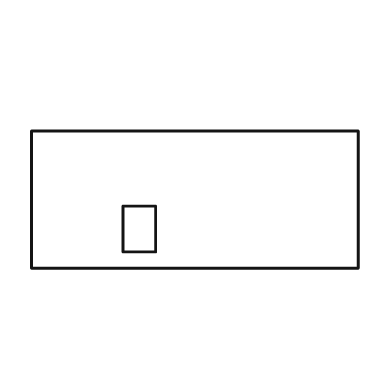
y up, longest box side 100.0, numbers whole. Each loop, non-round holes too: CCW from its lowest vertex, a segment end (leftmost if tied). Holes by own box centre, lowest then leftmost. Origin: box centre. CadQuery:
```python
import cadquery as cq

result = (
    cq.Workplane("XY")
    .moveTo(-50.0, -21.0)
    .lineTo(50.0, -21.0)
    .lineTo(50.0, 21.0)
    .lineTo(-50.0, 21.0)
    .close()
    .moveTo(-22.0, -16.0)
    .lineTo(-12.0, -16.0)
    .lineTo(-12.0, -2.0)
    .lineTo(-22.0, -2.0)
    .close()
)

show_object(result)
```